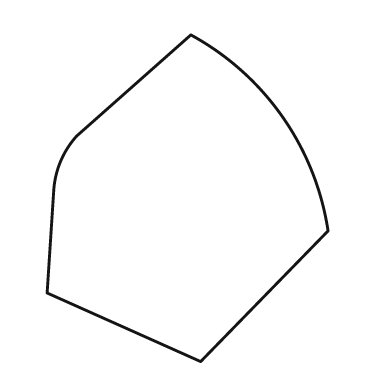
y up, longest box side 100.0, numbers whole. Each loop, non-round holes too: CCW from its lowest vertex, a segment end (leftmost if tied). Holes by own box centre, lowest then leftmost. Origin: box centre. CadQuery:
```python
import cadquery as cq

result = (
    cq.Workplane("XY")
    .moveTo(4.0, -50.0)
    .lineTo(43.0, -10.0)
    .threePointArc((29.0, 25.0), (1.0, 50.0))
    .lineTo(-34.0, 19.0)
    .threePointArc((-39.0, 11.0), (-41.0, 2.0))
    .lineTo(-43.0, -29.0)
    .close()
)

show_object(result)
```